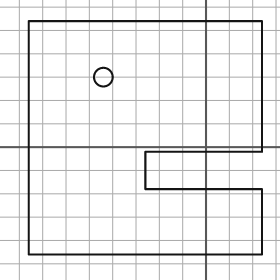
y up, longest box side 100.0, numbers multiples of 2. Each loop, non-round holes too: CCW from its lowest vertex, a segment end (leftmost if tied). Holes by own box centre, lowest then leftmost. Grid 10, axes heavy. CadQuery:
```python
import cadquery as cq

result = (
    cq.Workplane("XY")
    .moveTo(-76.0, -46.0)
    .lineTo(24.0, -46.0)
    .lineTo(24.0, -18.0)
    .lineTo(-26.0, -18.0)
    .lineTo(-26.0, -2.0)
    .lineTo(24.0, -2.0)
    .lineTo(24.0, 54.0)
    .lineTo(-76.0, 54.0)
    .close()
    .moveTo(-44.0, 30.0)
    .circle(4.0)
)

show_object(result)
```